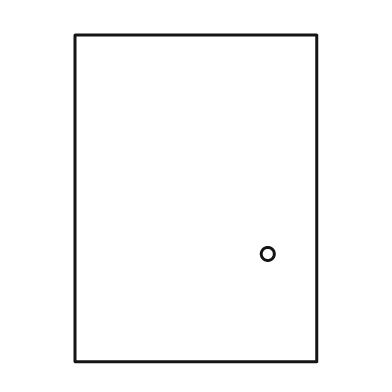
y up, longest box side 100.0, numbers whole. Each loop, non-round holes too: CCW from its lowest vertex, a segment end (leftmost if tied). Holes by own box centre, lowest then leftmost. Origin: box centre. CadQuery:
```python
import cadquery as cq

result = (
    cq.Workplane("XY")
    .moveTo(-37.0, -50.0)
    .lineTo(37.0, -50.0)
    .lineTo(37.0, 50.0)
    .lineTo(-37.0, 50.0)
    .close()
    .moveTo(22.0, -17.0)
    .circle(2.0)
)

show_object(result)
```